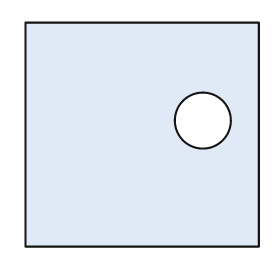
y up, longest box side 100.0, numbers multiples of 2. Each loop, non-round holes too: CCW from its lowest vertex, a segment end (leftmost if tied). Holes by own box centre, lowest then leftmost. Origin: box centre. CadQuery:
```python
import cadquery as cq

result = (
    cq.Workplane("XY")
    .moveTo(-50.0, -48.0)
    .lineTo(50.0, -48.0)
    .lineTo(50.0, 48.0)
    .lineTo(-50.0, 48.0)
    .close()
    .moveTo(26.0, 6.0)
    .circle(12.0)
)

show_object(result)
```